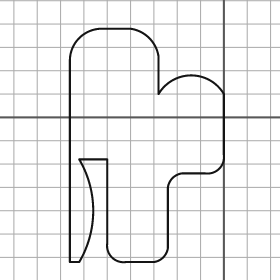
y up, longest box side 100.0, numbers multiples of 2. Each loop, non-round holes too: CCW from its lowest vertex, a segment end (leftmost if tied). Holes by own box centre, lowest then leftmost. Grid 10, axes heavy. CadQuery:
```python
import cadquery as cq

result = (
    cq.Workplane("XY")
    .moveTo(-66.0, -62.0)
    .lineTo(-62.0, -62.0)
    .threePointArc((-56.0, -40.0), (-62.0, -18.0))
    .lineTo(-50.0, -18.0)
    .lineTo(-50.0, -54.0)
    .threePointArc((-48.0, -60.0), (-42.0, -62.0))
    .lineTo(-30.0, -62.0)
    .threePointArc((-26.0, -60.0), (-24.0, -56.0))
    .lineTo(-24.0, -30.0)
    .threePointArc((-22.0, -26.0), (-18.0, -24.0))
    .lineTo(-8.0, -24.0)
    .threePointArc((-2.0, -22.0), (0.0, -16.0))
    .lineTo(0.0, 10.0)
    .threePointArc((-14.0, 18.0), (-28.0, 10.0))
    .lineTo(-28.0, 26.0)
    .threePointArc((-32.0, 34.0), (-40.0, 38.0))
    .lineTo(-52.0, 38.0)
    .threePointArc((-62.0, 34.0), (-66.0, 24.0))
    .close()
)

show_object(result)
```